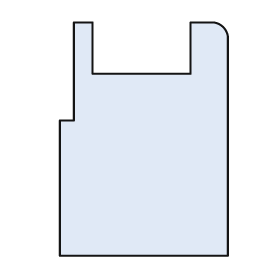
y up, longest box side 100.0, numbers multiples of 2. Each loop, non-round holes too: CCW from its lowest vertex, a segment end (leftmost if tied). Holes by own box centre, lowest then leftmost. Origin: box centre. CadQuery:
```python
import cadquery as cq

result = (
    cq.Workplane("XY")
    .moveTo(-36.0, -50.0)
    .lineTo(36.0, -50.0)
    .lineTo(36.0, 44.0)
    .threePointArc((34.0, 48.0), (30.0, 50.0))
    .lineTo(20.0, 50.0)
    .lineTo(20.0, 28.0)
    .lineTo(-22.0, 28.0)
    .lineTo(-22.0, 50.0)
    .lineTo(-30.0, 50.0)
    .lineTo(-30.0, 8.0)
    .lineTo(-36.0, 8.0)
    .close()
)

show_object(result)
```